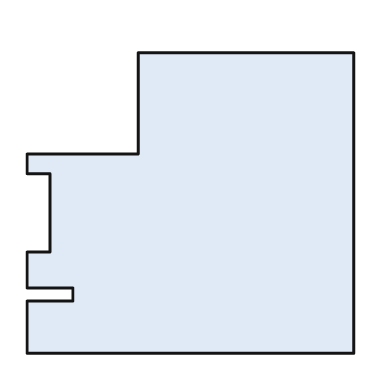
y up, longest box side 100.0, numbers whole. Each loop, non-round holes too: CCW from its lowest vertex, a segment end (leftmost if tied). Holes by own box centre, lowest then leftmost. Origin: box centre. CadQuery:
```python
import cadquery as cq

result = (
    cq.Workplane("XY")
    .moveTo(-50.0, -46.0)
    .lineTo(50.0, -46.0)
    .lineTo(50.0, 46.0)
    .lineTo(-16.0, 46.0)
    .lineTo(-16.0, 15.0)
    .lineTo(-50.0, 15.0)
    .lineTo(-50.0, 9.0)
    .lineTo(-43.0, 9.0)
    .lineTo(-43.0, -15.0)
    .lineTo(-50.0, -15.0)
    .lineTo(-50.0, -26.0)
    .lineTo(-36.0, -26.0)
    .lineTo(-36.0, -30.0)
    .lineTo(-50.0, -30.0)
    .close()
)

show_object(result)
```